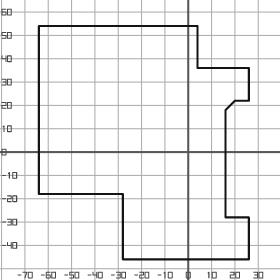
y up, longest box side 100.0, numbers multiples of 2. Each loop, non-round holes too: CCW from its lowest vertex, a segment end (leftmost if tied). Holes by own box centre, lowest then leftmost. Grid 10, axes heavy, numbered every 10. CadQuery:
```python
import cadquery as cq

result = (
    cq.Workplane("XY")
    .moveTo(-28.0, -46.0)
    .lineTo(26.0, -46.0)
    .lineTo(26.0, -28.0)
    .lineTo(16.0, -28.0)
    .lineTo(16.0, 18.0)
    .lineTo(20.0, 22.0)
    .lineTo(26.0, 22.0)
    .lineTo(26.0, 36.0)
    .lineTo(4.0, 36.0)
    .lineTo(4.0, 54.0)
    .lineTo(-64.0, 54.0)
    .lineTo(-64.0, -18.0)
    .lineTo(-28.0, -18.0)
    .close()
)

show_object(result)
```